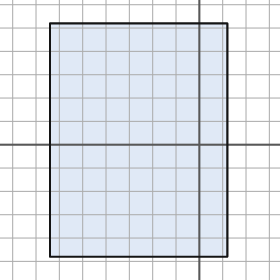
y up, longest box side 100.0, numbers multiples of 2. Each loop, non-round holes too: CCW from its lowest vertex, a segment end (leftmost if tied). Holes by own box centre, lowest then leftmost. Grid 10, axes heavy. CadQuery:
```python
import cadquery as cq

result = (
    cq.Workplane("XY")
    .moveTo(-64.0, -48.0)
    .lineTo(12.0, -48.0)
    .lineTo(12.0, 52.0)
    .lineTo(-64.0, 52.0)
    .close()
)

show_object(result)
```